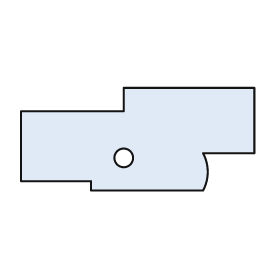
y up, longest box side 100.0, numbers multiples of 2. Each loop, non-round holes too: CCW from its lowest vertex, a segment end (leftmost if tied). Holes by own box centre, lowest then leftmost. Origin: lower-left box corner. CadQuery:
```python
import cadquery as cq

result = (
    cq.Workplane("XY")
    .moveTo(30.0, 0.0)
    .lineTo(78.0, 0.0)
    .threePointArc((80.0, 8.0), (78.0, 16.0))
    .lineTo(100.0, 16.0)
    .lineTo(100.0, 44.0)
    .lineTo(44.0, 44.0)
    .lineTo(44.0, 34.0)
    .lineTo(0.0, 34.0)
    .lineTo(0.0, 4.0)
    .lineTo(30.0, 4.0)
    .close()
    .moveTo(44.0, 14.0)
    .circle(4.0)
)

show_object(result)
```